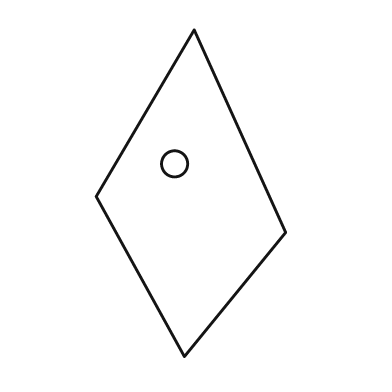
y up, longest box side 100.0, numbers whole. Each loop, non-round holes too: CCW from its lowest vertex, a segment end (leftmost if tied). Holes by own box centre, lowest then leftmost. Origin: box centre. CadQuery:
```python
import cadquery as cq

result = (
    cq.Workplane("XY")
    .moveTo(-2.0, -50.0)
    .lineTo(29.0, -12.0)
    .lineTo(1.0, 50.0)
    .lineTo(-29.0, -1.0)
    .close()
    .moveTo(-5.0, 9.0)
    .circle(4.0)
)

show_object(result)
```